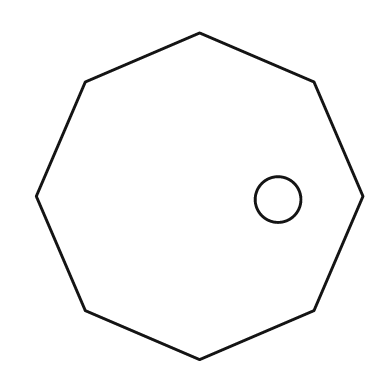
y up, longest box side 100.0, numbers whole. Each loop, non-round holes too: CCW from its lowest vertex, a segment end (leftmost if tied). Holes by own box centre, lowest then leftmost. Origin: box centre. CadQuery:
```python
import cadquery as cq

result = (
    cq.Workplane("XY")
    .moveTo(0.0, -50.0)
    .lineTo(35.0, -35.0)
    .lineTo(50.0, 0.0)
    .lineTo(35.0, 35.0)
    .lineTo(0.0, 50.0)
    .lineTo(-35.0, 35.0)
    .lineTo(-50.0, 0.0)
    .lineTo(-35.0, -35.0)
    .close()
    .moveTo(24.0, -1.0)
    .circle(7.0)
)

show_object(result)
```